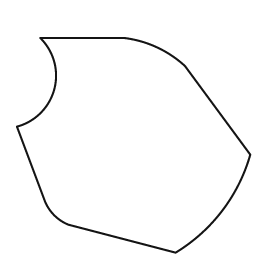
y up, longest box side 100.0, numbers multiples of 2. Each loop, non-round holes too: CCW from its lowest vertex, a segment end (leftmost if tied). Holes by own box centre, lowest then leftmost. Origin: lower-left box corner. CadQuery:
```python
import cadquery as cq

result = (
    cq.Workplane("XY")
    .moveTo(68.0, 0.0)
    .threePointArc((88.0, 18.0), (100.0, 42.0))
    .lineTo(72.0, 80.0)
    .threePointArc((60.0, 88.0), (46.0, 92.0))
    .lineTo(10.0, 92.0)
    .threePointArc((16.0, 70.0), (0.0, 54.0))
    .lineTo(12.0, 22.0)
    .threePointArc((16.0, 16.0), (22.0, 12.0))
    .close()
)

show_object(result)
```